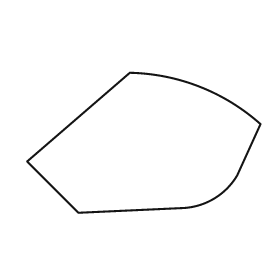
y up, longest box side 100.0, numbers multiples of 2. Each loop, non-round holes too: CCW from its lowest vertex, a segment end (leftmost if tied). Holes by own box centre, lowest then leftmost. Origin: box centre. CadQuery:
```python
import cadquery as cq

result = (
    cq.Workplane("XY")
    .moveTo(-28.0, -30.0)
    .lineTo(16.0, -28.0)
    .threePointArc((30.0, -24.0), (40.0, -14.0))
    .lineTo(50.0, 8.0)
    .threePointArc((24.0, 24.0), (-6.0, 30.0))
    .lineTo(-50.0, -8.0)
    .close()
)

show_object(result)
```